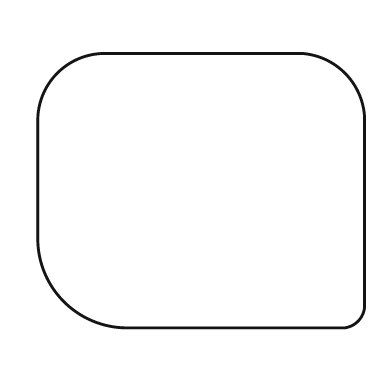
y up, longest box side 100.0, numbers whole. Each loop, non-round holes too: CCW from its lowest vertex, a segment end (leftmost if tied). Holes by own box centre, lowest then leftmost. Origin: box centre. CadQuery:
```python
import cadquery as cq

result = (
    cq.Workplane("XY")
    .moveTo(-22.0, -42.0)
    .lineTo(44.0, -42.0)
    .threePointArc((48.0, -40.0), (50.0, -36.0))
    .lineTo(50.0, 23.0)
    .threePointArc((44.0, 36.0), (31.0, 42.0))
    .lineTo(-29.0, 42.0)
    .threePointArc((-44.0, 36.0), (-50.0, 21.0))
    .lineTo(-50.0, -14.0)
    .threePointArc((-42.0, -34.0), (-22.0, -42.0))
    .close()
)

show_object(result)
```